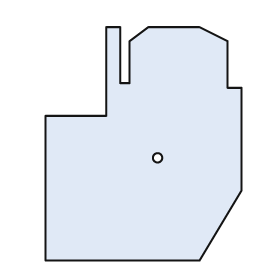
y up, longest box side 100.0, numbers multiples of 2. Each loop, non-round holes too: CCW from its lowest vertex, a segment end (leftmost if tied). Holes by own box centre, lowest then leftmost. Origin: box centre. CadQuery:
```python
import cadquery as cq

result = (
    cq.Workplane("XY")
    .moveTo(-42.0, -50.0)
    .lineTo(24.0, -50.0)
    .lineTo(42.0, -20.0)
    .lineTo(42.0, 24.0)
    .lineTo(36.0, 24.0)
    .lineTo(36.0, 44.0)
    .lineTo(24.0, 50.0)
    .lineTo(2.0, 50.0)
    .lineTo(-6.0, 44.0)
    .lineTo(-6.0, 26.0)
    .lineTo(-10.0, 26.0)
    .lineTo(-10.0, 50.0)
    .lineTo(-16.0, 50.0)
    .lineTo(-16.0, 12.0)
    .lineTo(-42.0, 12.0)
    .close()
    .moveTo(6.0, -6.0)
    .circle(2.0)
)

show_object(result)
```